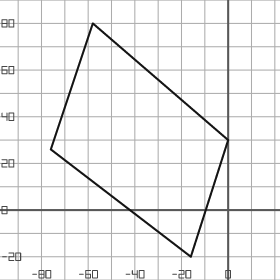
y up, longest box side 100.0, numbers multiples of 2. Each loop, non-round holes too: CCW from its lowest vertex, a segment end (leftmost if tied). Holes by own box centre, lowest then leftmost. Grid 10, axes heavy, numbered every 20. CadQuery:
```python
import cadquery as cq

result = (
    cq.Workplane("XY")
    .moveTo(-16.0, -20.0)
    .lineTo(0.0, 30.0)
    .lineTo(-58.0, 80.0)
    .lineTo(-76.0, 26.0)
    .close()
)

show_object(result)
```